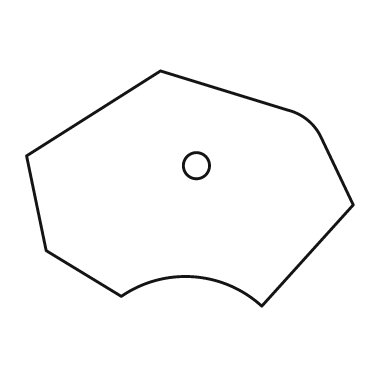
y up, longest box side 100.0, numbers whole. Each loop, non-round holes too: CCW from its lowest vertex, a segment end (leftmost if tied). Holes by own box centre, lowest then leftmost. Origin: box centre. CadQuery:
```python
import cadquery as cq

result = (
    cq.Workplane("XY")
    .moveTo(22.0, -36.0)
    .lineTo(50.0, -5.0)
    .lineTo(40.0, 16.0)
    .threePointArc((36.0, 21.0), (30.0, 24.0))
    .lineTo(-9.0, 36.0)
    .lineTo(-50.0, 10.0)
    .lineTo(-44.0, -19.0)
    .lineTo(-21.0, -33.0)
    .threePointArc((1.0, -27.0), (22.0, -36.0))
    .close()
    .moveTo(2.0, 7.0)
    .circle(4.0)
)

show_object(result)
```